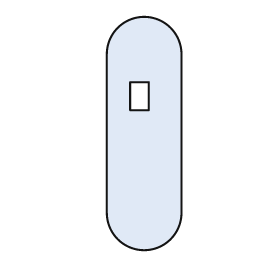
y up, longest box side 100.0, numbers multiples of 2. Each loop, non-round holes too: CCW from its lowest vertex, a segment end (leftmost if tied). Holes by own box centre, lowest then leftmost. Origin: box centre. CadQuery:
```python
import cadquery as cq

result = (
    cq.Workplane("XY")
    .moveTo(-16.0, -34.0)
    .threePointArc((0.0, -50.0), (16.0, -34.0))
    .lineTo(16.0, 34.0)
    .threePointArc((0.0, 50.0), (-16.0, 34.0))
    .close()
    .moveTo(-6.0, 10.0)
    .lineTo(2.0, 10.0)
    .lineTo(2.0, 22.0)
    .lineTo(-6.0, 22.0)
    .close()
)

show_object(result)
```